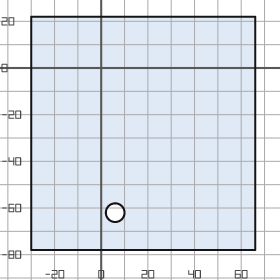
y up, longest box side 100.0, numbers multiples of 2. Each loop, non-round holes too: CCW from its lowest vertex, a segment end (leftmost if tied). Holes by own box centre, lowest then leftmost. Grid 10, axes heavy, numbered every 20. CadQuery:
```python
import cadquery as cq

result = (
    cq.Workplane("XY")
    .moveTo(-30.0, -78.0)
    .lineTo(66.0, -78.0)
    .lineTo(66.0, 22.0)
    .lineTo(-30.0, 22.0)
    .close()
    .moveTo(6.0, -62.0)
    .circle(4.0)
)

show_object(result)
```